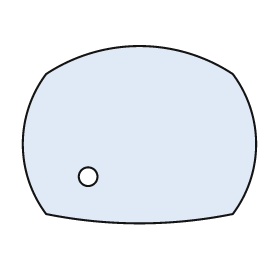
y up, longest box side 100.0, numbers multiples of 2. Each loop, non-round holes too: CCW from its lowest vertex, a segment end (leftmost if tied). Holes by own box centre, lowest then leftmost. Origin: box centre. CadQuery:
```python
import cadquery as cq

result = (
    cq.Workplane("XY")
    .moveTo(-40.0, -34.0)
    .threePointArc((0.0, -38.0), (40.0, -34.0))
    .threePointArc((50.0, -4.0), (40.0, 26.0))
    .threePointArc((0.0, 38.0), (-40.0, 26.0))
    .threePointArc((-50.0, -4.0), (-40.0, -34.0))
    .close()
    .moveTo(-22.0, -18.0)
    .circle(4.0)
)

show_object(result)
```